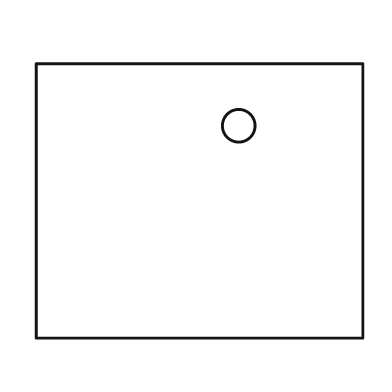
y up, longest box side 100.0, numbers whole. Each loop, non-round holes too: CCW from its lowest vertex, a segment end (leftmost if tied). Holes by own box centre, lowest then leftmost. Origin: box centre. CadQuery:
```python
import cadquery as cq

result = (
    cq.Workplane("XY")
    .moveTo(-50.0, -42.0)
    .lineTo(50.0, -42.0)
    .lineTo(50.0, 42.0)
    .lineTo(-50.0, 42.0)
    .close()
    .moveTo(12.0, 23.0)
    .circle(5.0)
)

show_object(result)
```